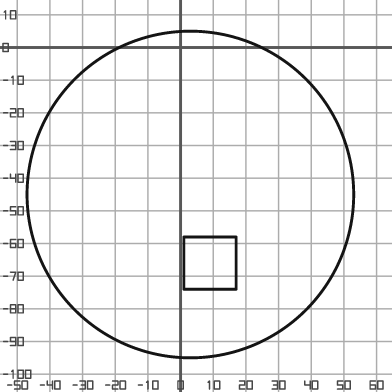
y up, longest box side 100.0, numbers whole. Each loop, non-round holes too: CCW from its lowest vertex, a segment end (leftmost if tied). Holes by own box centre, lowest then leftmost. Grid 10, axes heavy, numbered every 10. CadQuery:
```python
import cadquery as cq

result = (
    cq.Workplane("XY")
    .moveTo(3.0, -45.0)
    .circle(50.0)
    .moveTo(1.0, -74.0)
    .lineTo(17.0, -74.0)
    .lineTo(17.0, -58.0)
    .lineTo(1.0, -58.0)
    .close()
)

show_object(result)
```